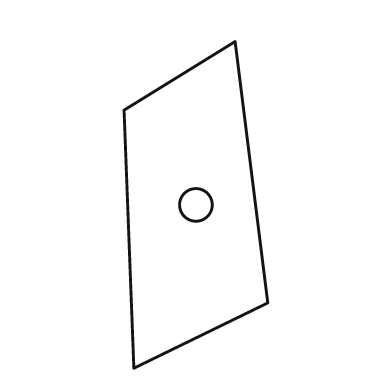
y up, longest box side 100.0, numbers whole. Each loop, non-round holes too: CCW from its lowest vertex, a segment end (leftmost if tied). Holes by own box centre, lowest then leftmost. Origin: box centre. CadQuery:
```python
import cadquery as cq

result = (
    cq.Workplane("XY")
    .moveTo(-19.0, -50.0)
    .lineTo(22.0, -30.0)
    .lineTo(12.0, 50.0)
    .lineTo(-22.0, 29.0)
    .close()
    .moveTo(0.0, 0.0)
    .circle(5.0)
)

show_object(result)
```